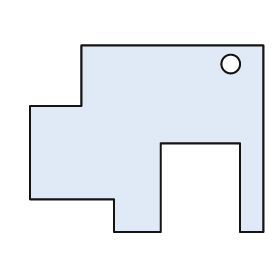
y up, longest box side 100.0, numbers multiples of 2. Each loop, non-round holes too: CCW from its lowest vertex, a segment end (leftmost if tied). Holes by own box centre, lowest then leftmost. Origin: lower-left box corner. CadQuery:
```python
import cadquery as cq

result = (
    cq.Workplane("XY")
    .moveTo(36.0, 0.0)
    .lineTo(56.0, 0.0)
    .lineTo(56.0, 38.0)
    .lineTo(90.0, 38.0)
    .lineTo(90.0, 0.0)
    .lineTo(100.0, 0.0)
    .lineTo(100.0, 80.0)
    .lineTo(22.0, 80.0)
    .lineTo(22.0, 54.0)
    .lineTo(0.0, 54.0)
    .lineTo(0.0, 14.0)
    .lineTo(36.0, 14.0)
    .close()
    .moveTo(86.0, 72.0)
    .circle(4.0)
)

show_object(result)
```